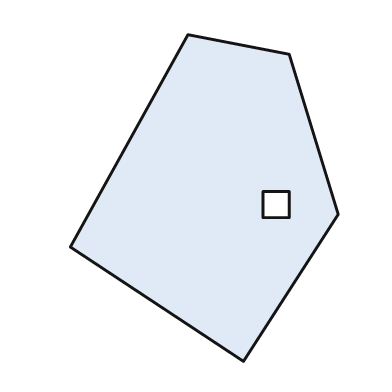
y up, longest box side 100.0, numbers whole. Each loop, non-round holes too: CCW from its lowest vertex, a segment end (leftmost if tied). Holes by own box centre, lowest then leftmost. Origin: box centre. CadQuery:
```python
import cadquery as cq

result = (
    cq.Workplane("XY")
    .moveTo(12.0, -50.0)
    .lineTo(41.0, -5.0)
    .lineTo(26.0, 44.0)
    .lineTo(-5.0, 50.0)
    .lineTo(-41.0, -15.0)
    .close()
    .moveTo(18.0, -6.0)
    .lineTo(26.0, -6.0)
    .lineTo(26.0, 2.0)
    .lineTo(18.0, 2.0)
    .close()
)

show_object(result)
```